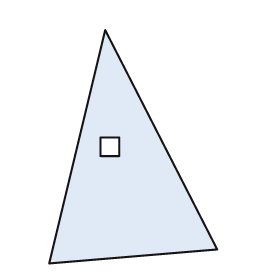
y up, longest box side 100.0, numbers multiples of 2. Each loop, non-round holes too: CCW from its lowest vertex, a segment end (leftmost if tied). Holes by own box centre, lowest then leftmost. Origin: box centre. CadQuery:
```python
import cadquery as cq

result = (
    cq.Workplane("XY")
    .moveTo(-36.0, -50.0)
    .lineTo(36.0, -44.0)
    .lineTo(-12.0, 50.0)
    .close()
    .moveTo(-14.0, -4.0)
    .lineTo(-6.0, -4.0)
    .lineTo(-6.0, 4.0)
    .lineTo(-14.0, 4.0)
    .close()
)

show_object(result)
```